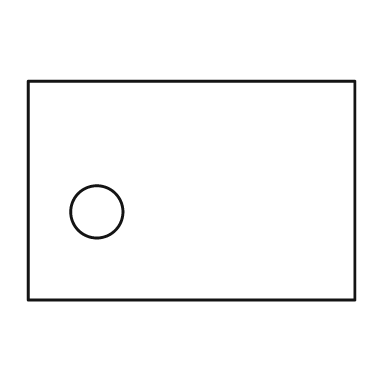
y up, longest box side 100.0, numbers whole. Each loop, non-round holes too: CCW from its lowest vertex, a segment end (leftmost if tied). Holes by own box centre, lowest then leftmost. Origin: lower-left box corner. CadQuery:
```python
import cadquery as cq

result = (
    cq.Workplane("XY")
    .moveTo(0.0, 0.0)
    .lineTo(100.0, 0.0)
    .lineTo(100.0, 67.0)
    .lineTo(0.0, 67.0)
    .close()
    .moveTo(21.0, 27.0)
    .circle(8.0)
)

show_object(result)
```